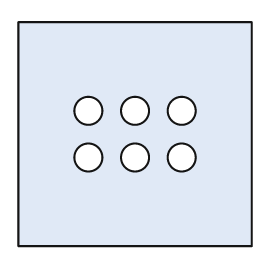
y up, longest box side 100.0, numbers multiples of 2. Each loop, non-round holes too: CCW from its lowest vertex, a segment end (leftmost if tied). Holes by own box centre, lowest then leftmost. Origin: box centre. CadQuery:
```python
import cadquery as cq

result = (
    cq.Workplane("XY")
    .moveTo(-50.0, -48.0)
    .lineTo(50.0, -48.0)
    .lineTo(50.0, 48.0)
    .lineTo(-50.0, 48.0)
    .close()
    .moveTo(-20.0, -10.0)
    .circle(6.0)
    .moveTo(0.0, -10.0)
    .circle(6.0)
    .moveTo(20.0, -10.0)
    .circle(6.0)
    .moveTo(-20.0, 10.0)
    .circle(6.0)
    .moveTo(0.0, 10.0)
    .circle(6.0)
    .moveTo(20.0, 10.0)
    .circle(6.0)
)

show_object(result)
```